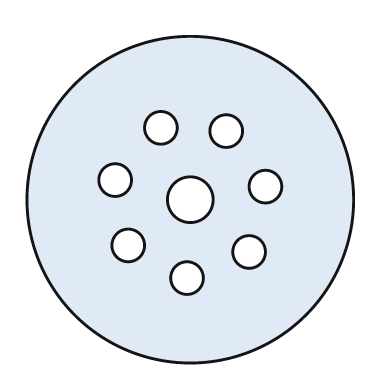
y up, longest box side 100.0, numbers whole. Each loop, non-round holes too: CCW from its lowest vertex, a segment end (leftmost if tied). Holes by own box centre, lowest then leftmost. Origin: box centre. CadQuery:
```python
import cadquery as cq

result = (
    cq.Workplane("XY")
    .moveTo(0.0, 0.0)
    .circle(50.0)
    .moveTo(-1.0, -24.0)
    .circle(5.0)
    .moveTo(18.0, -16.0)
    .circle(5.0)
    .moveTo(-19.0, -14.0)
    .circle(5.0)
    .moveTo(0.0, 0.0)
    .circle(7.0)
    .moveTo(23.0, 4.0)
    .circle(5.0)
    .moveTo(-23.0, 6.0)
    .circle(5.0)
    .moveTo(11.0, 21.0)
    .circle(5.0)
    .moveTo(-9.0, 22.0)
    .circle(5.0)
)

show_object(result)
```